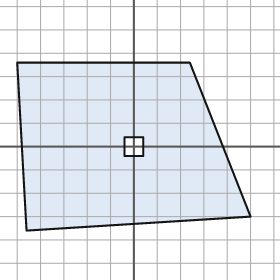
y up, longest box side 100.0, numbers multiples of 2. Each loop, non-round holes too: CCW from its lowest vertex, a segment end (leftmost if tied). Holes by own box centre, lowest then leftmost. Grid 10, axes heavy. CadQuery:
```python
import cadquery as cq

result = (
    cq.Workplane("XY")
    .moveTo(-46.0, -36.0)
    .lineTo(50.0, -30.0)
    .lineTo(24.0, 36.0)
    .lineTo(-50.0, 36.0)
    .close()
    .moveTo(-4.0, -4.0)
    .lineTo(4.0, -4.0)
    .lineTo(4.0, 4.0)
    .lineTo(-4.0, 4.0)
    .close()
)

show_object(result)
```